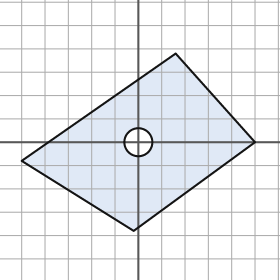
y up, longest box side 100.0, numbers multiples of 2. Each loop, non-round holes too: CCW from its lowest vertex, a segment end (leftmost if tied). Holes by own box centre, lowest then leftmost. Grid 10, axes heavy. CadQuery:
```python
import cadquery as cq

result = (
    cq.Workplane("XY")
    .moveTo(-2.0, -38.0)
    .lineTo(50.0, 0.0)
    .lineTo(16.0, 38.0)
    .lineTo(-50.0, -8.0)
    .close()
    .moveTo(0.0, 0.0)
    .circle(6.0)
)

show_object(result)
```